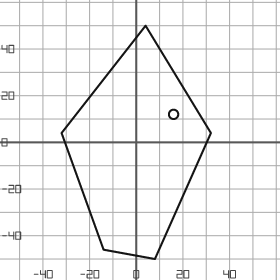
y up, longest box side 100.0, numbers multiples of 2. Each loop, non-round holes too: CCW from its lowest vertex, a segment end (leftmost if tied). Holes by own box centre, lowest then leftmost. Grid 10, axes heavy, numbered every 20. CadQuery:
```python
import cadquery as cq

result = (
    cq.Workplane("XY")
    .moveTo(8.0, -50.0)
    .lineTo(32.0, 4.0)
    .lineTo(4.0, 50.0)
    .lineTo(-32.0, 4.0)
    .lineTo(-14.0, -46.0)
    .close()
    .moveTo(16.0, 12.0)
    .circle(2.0)
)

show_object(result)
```